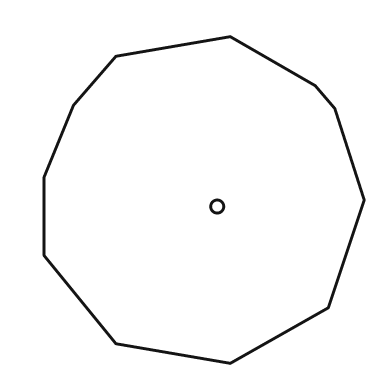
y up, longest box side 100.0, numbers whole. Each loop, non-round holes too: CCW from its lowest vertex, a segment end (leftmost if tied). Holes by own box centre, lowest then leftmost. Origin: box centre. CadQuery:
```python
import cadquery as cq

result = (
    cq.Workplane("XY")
    .moveTo(8.0, -50.0)
    .lineTo(38.0, -33.0)
    .lineTo(49.0, 0.0)
    .lineTo(40.0, 28.0)
    .lineTo(34.0, 35.0)
    .lineTo(8.0, 50.0)
    .lineTo(-27.0, 44.0)
    .lineTo(-40.0, 29.0)
    .lineTo(-49.0, 7.0)
    .lineTo(-49.0, -17.0)
    .lineTo(-27.0, -44.0)
    .close()
    .moveTo(4.0, -2.0)
    .circle(2.0)
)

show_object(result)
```